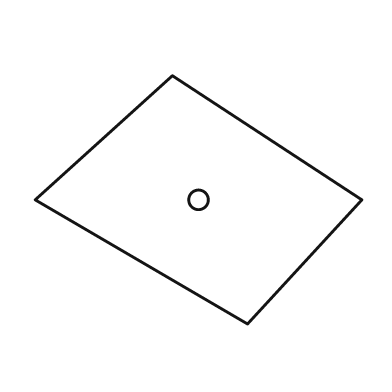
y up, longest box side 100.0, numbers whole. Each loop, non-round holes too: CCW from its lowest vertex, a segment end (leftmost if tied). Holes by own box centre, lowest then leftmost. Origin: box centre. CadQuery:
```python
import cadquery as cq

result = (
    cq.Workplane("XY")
    .moveTo(15.0, -38.0)
    .lineTo(50.0, 0.0)
    .lineTo(-8.0, 38.0)
    .lineTo(-50.0, 0.0)
    .close()
    .moveTo(0.0, 0.0)
    .circle(3.0)
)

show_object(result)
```